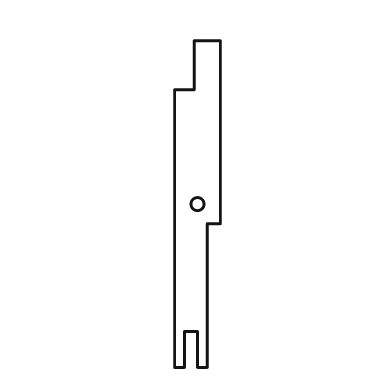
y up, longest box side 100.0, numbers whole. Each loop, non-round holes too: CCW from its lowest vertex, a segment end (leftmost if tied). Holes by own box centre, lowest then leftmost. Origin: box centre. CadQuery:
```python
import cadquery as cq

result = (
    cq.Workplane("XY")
    .moveTo(-7.0, -50.0)
    .lineTo(-4.0, -50.0)
    .lineTo(-4.0, -39.0)
    .lineTo(0.0, -39.0)
    .lineTo(0.0, -50.0)
    .lineTo(3.0, -50.0)
    .lineTo(3.0, -6.0)
    .lineTo(7.0, -6.0)
    .lineTo(7.0, 50.0)
    .lineTo(-1.0, 50.0)
    .lineTo(-1.0, 35.0)
    .lineTo(-7.0, 35.0)
    .close()
    .moveTo(0.0, 0.0)
    .circle(2.0)
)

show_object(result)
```